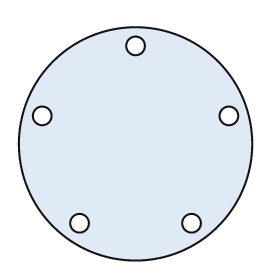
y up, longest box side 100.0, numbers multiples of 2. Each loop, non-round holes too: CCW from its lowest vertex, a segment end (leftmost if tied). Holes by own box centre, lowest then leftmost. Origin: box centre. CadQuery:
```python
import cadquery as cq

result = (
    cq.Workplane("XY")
    .moveTo(0.0, 0.0)
    .circle(50.0)
    .moveTo(-24.0, -34.0)
    .circle(4.0)
    .moveTo(24.0, -34.0)
    .circle(4.0)
    .moveTo(-40.0, 12.0)
    .circle(4.0)
    .moveTo(40.0, 12.0)
    .circle(4.0)
    .moveTo(0.0, 42.0)
    .circle(4.0)
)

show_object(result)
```